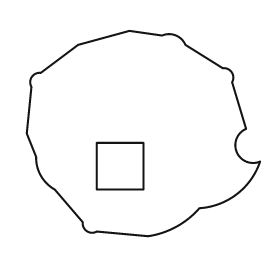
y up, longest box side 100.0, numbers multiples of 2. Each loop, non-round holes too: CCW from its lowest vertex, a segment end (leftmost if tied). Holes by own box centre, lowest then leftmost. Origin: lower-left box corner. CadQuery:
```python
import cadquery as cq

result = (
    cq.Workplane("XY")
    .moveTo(52.0, 0.0)
    .threePointArc((64.0, 4.0), (74.0, 12.0))
    .threePointArc((90.0, 18.0), (100.0, 32.0))
    .threePointArc((90.0, 36.0), (94.0, 46.0))
    .lineTo(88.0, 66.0)
    .threePointArc((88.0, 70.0), (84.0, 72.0))
    .lineTo(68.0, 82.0)
    .threePointArc((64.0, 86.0), (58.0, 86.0))
    .lineTo(44.0, 88.0)
    .lineTo(22.0, 82.0)
    .lineTo(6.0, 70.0)
    .threePointArc((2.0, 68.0), (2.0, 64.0))
    .lineTo(0.0, 44.0)
    .lineTo(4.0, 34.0)
    .threePointArc((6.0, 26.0), (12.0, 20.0))
    .lineTo(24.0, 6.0)
    .threePointArc((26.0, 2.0), (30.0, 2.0))
    .close()
    .moveTo(30.0, 20.0)
    .lineTo(50.0, 20.0)
    .lineTo(50.0, 40.0)
    .lineTo(30.0, 40.0)
    .close()
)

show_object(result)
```